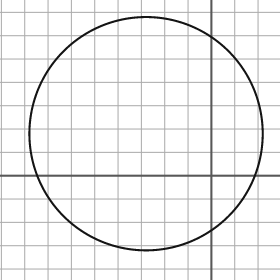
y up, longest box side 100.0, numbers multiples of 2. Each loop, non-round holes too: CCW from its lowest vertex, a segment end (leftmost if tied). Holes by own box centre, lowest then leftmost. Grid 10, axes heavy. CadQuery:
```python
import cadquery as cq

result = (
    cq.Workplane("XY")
    .moveTo(-28.0, 18.0)
    .circle(50.0)
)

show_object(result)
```